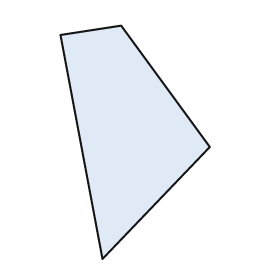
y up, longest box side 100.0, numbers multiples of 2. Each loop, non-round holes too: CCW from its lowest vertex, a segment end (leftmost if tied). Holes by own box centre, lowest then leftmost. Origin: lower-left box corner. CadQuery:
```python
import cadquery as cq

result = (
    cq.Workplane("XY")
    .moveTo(18.0, 0.0)
    .lineTo(64.0, 48.0)
    .lineTo(26.0, 100.0)
    .lineTo(0.0, 96.0)
    .close()
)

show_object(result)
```